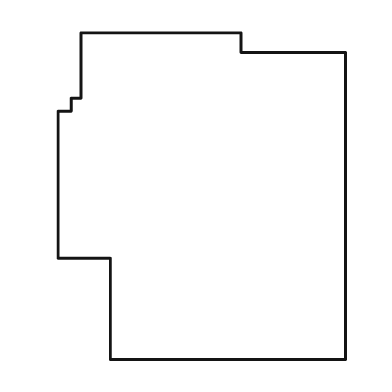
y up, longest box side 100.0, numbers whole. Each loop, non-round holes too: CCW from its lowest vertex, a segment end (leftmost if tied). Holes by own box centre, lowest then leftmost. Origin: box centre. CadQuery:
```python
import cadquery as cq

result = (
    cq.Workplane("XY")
    .moveTo(-28.0, -50.0)
    .lineTo(44.0, -50.0)
    .lineTo(44.0, 44.0)
    .lineTo(12.0, 44.0)
    .lineTo(12.0, 50.0)
    .lineTo(-37.0, 50.0)
    .lineTo(-37.0, 30.0)
    .lineTo(-40.0, 30.0)
    .lineTo(-40.0, 26.0)
    .lineTo(-44.0, 26.0)
    .lineTo(-44.0, -19.0)
    .lineTo(-28.0, -19.0)
    .close()
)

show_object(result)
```